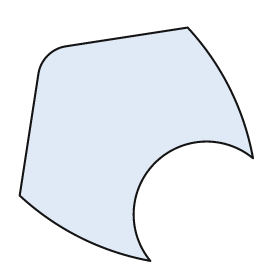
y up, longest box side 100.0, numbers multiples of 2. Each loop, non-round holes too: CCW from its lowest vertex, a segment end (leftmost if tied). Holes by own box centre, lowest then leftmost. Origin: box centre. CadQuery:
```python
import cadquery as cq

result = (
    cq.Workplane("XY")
    .moveTo(6.0, -50.0)
    .threePointArc((8.0, -8.0), (50.0, -6.0))
    .threePointArc((40.0, 24.0), (22.0, 50.0))
    .lineTo(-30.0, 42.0)
    .threePointArc((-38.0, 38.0), (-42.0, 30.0))
    .lineTo(-50.0, -22.0)
    .threePointArc((-24.0, -40.0), (6.0, -50.0))
    .close()
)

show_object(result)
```